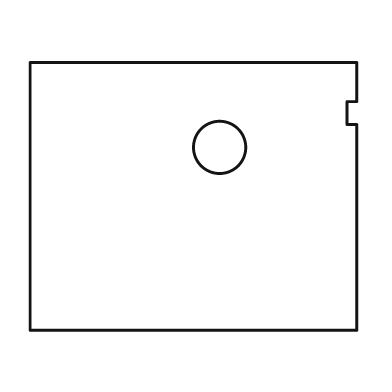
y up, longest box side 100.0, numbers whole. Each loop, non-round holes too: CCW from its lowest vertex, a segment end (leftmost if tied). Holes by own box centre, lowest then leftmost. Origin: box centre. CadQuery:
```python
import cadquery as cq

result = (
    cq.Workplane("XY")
    .moveTo(-50.0, -41.0)
    .lineTo(50.0, -41.0)
    .lineTo(50.0, 22.0)
    .lineTo(47.0, 22.0)
    .lineTo(47.0, 29.0)
    .lineTo(50.0, 29.0)
    .lineTo(50.0, 41.0)
    .lineTo(-50.0, 41.0)
    .close()
    .moveTo(8.0, 15.0)
    .circle(8.0)
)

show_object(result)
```